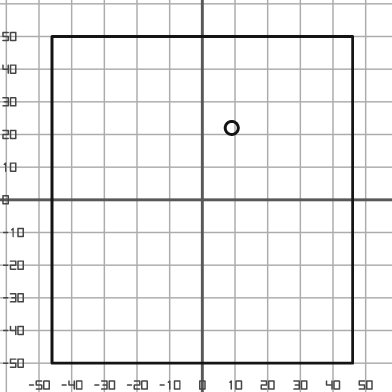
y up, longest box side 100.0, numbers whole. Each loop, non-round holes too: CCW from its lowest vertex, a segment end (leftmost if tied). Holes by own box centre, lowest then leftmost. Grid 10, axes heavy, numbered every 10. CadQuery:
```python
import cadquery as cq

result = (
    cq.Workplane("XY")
    .moveTo(-46.0, -50.0)
    .lineTo(46.0, -50.0)
    .lineTo(46.0, 50.0)
    .lineTo(-46.0, 50.0)
    .close()
    .moveTo(9.0, 22.0)
    .circle(2.0)
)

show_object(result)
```